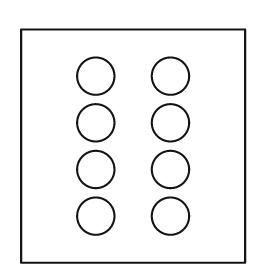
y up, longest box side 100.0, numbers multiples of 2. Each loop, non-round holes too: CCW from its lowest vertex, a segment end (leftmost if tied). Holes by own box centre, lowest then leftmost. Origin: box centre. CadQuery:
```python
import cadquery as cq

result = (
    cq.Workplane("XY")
    .moveTo(-48.0, -50.0)
    .lineTo(48.0, -50.0)
    .lineTo(48.0, 50.0)
    .lineTo(-48.0, 50.0)
    .close()
    .moveTo(-16.0, -30.0)
    .circle(8.0)
    .moveTo(16.0, -30.0)
    .circle(8.0)
    .moveTo(-16.0, -10.0)
    .circle(8.0)
    .moveTo(16.0, -10.0)
    .circle(8.0)
    .moveTo(-16.0, 10.0)
    .circle(8.0)
    .moveTo(16.0, 10.0)
    .circle(8.0)
    .moveTo(-16.0, 30.0)
    .circle(8.0)
    .moveTo(16.0, 30.0)
    .circle(8.0)
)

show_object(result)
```